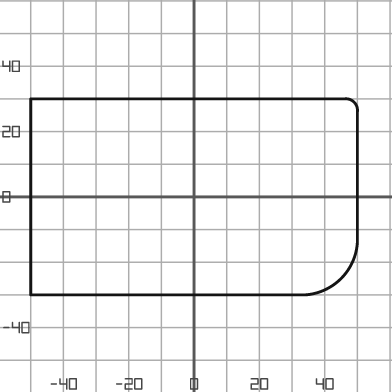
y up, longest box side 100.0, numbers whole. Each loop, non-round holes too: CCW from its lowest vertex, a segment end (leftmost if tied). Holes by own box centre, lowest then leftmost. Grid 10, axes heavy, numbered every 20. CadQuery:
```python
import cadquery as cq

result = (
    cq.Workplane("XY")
    .moveTo(-50.0, -30.0)
    .lineTo(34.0, -30.0)
    .threePointArc((45.0, -25.0), (50.0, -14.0))
    .lineTo(50.0, 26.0)
    .threePointArc((49.0, 29.0), (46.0, 30.0))
    .lineTo(-50.0, 30.0)
    .close()
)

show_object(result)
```